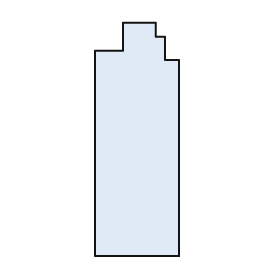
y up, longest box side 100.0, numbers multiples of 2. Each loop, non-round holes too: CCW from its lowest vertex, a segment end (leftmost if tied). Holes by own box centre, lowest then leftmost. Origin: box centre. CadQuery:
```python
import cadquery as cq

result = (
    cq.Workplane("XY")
    .moveTo(-18.0, -50.0)
    .lineTo(18.0, -50.0)
    .lineTo(18.0, 34.0)
    .lineTo(12.0, 34.0)
    .lineTo(12.0, 44.0)
    .lineTo(8.0, 44.0)
    .lineTo(8.0, 50.0)
    .lineTo(-6.0, 50.0)
    .lineTo(-6.0, 38.0)
    .lineTo(-18.0, 38.0)
    .close()
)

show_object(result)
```